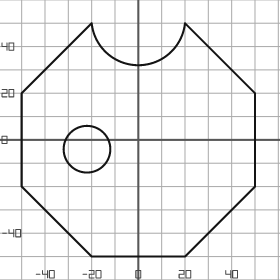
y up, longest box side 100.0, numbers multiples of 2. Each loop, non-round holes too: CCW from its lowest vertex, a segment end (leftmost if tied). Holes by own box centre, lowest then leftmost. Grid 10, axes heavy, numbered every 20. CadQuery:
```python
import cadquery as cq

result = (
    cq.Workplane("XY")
    .moveTo(-20.0, -50.0)
    .lineTo(20.0, -50.0)
    .lineTo(50.0, -20.0)
    .lineTo(50.0, 20.0)
    .lineTo(20.0, 50.0)
    .threePointArc((0.0, 32.0), (-20.0, 50.0))
    .lineTo(-50.0, 20.0)
    .lineTo(-50.0, -20.0)
    .close()
    .moveTo(-22.0, -4.0)
    .circle(10.0)
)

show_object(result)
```